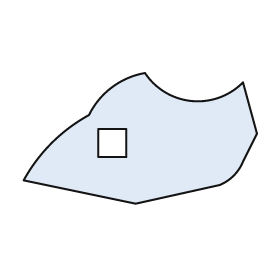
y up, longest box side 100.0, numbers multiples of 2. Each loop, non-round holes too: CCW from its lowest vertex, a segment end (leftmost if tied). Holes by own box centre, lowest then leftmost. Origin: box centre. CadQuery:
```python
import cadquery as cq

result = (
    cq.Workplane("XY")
    .moveTo(-2.0, -28.0)
    .lineTo(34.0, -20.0)
    .threePointArc((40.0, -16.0), (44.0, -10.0))
    .lineTo(50.0, 2.0)
    .lineTo(44.0, 24.0)
    .threePointArc((22.0, 16.0), (2.0, 28.0))
    .threePointArc((-12.0, 22.0), (-22.0, 10.0))
    .threePointArc((-38.0, -2.0), (-50.0, -18.0))
    .close()
    .moveTo(-18.0, -8.0)
    .lineTo(-6.0, -8.0)
    .lineTo(-6.0, 4.0)
    .lineTo(-18.0, 4.0)
    .close()
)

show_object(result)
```